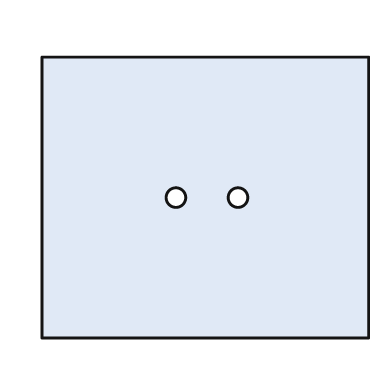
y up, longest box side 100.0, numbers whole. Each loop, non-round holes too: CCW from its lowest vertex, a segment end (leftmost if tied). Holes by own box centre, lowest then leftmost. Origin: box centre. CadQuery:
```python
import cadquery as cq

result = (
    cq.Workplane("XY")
    .moveTo(-50.0, -43.0)
    .lineTo(50.0, -43.0)
    .lineTo(50.0, 43.0)
    .lineTo(-50.0, 43.0)
    .close()
    .moveTo(-9.0, 0.0)
    .circle(3.0)
    .moveTo(10.0, 0.0)
    .circle(3.0)
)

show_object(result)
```